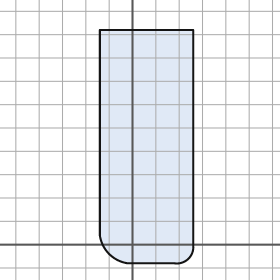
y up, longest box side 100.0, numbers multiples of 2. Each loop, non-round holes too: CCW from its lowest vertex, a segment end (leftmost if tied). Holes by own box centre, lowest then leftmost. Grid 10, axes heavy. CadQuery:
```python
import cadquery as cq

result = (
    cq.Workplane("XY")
    .moveTo(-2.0, -8.0)
    .lineTo(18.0, -8.0)
    .threePointArc((24.0, -6.0), (26.0, 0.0))
    .lineTo(26.0, 92.0)
    .lineTo(-14.0, 92.0)
    .lineTo(-14.0, 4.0)
    .threePointArc((-10.0, -4.0), (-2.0, -8.0))
    .close()
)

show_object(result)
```